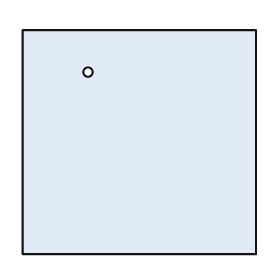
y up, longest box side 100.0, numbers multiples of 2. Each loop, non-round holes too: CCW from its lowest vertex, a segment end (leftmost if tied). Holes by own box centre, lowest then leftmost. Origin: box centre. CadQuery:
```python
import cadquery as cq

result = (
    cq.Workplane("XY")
    .moveTo(-50.0, -48.0)
    .lineTo(50.0, -48.0)
    .lineTo(50.0, 48.0)
    .lineTo(-50.0, 48.0)
    .close()
    .moveTo(-22.0, 30.0)
    .circle(2.0)
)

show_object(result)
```